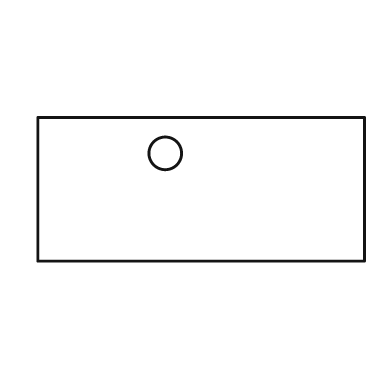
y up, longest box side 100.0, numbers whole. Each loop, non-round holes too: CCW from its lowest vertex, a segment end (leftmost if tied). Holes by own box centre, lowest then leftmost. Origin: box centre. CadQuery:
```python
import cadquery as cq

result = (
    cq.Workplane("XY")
    .moveTo(-50.0, -22.0)
    .lineTo(50.0, -22.0)
    .lineTo(50.0, 22.0)
    .lineTo(-50.0, 22.0)
    .close()
    .moveTo(-11.0, 11.0)
    .circle(5.0)
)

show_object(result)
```